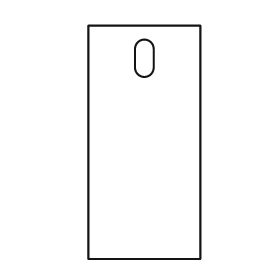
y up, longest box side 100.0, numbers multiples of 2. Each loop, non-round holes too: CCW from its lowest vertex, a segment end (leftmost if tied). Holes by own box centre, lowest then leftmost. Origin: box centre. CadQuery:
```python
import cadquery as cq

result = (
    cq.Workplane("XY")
    .moveTo(-24.0, -50.0)
    .lineTo(24.0, -50.0)
    .lineTo(24.0, 50.0)
    .lineTo(-24.0, 50.0)
    .close()
    .moveTo(-4.0, 32.0)
    .threePointArc((0.0, 28.0), (4.0, 32.0))
    .lineTo(4.0, 40.0)
    .threePointArc((0.0, 44.0), (-4.0, 40.0))
    .close()
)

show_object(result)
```